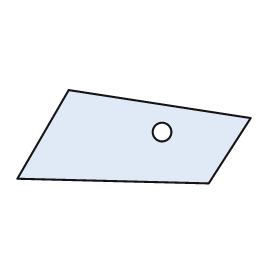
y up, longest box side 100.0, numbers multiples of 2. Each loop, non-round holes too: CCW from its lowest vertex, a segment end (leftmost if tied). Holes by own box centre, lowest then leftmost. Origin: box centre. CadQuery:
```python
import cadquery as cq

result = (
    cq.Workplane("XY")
    .moveTo(32.0, -20.0)
    .lineTo(50.0, 8.0)
    .lineTo(-28.0, 20.0)
    .lineTo(-50.0, -18.0)
    .close()
    .moveTo(12.0, 2.0)
    .circle(4.0)
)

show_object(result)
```